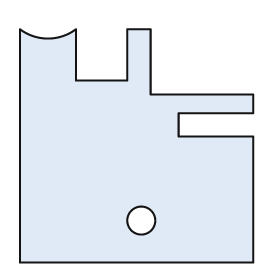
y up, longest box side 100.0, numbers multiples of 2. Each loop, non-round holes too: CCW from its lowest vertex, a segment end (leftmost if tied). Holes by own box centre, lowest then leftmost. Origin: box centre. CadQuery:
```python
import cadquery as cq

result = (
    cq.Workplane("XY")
    .moveTo(-50.0, -50.0)
    .lineTo(50.0, -50.0)
    .lineTo(50.0, 4.0)
    .lineTo(18.0, 4.0)
    .lineTo(18.0, 14.0)
    .lineTo(50.0, 14.0)
    .lineTo(50.0, 22.0)
    .lineTo(6.0, 22.0)
    .lineTo(6.0, 50.0)
    .lineTo(-4.0, 50.0)
    .lineTo(-4.0, 28.0)
    .lineTo(-26.0, 28.0)
    .lineTo(-26.0, 50.0)
    .threePointArc((-38.0, 46.0), (-50.0, 50.0))
    .close()
    .moveTo(2.0, -32.0)
    .circle(6.0)
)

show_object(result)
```